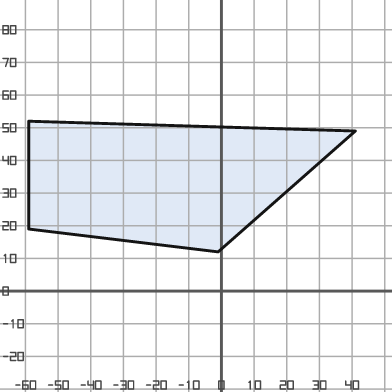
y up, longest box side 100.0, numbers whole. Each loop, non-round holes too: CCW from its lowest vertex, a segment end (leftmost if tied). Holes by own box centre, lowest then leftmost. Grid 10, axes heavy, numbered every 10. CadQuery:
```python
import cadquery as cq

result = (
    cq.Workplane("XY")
    .moveTo(-1.0, 12.0)
    .lineTo(41.0, 49.0)
    .lineTo(-59.0, 52.0)
    .lineTo(-59.0, 19.0)
    .close()
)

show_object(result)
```